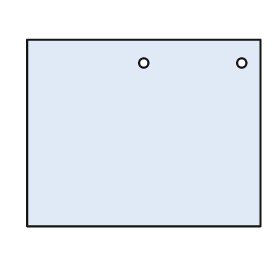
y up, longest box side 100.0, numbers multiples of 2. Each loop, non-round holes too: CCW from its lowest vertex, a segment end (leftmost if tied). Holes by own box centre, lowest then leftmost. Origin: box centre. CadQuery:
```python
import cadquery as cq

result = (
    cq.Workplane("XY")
    .moveTo(-50.0, -40.0)
    .lineTo(50.0, -40.0)
    .lineTo(50.0, 40.0)
    .lineTo(-50.0, 40.0)
    .close()
    .moveTo(0.0, 30.0)
    .circle(2.0)
    .moveTo(42.0, 30.0)
    .circle(2.0)
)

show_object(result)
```